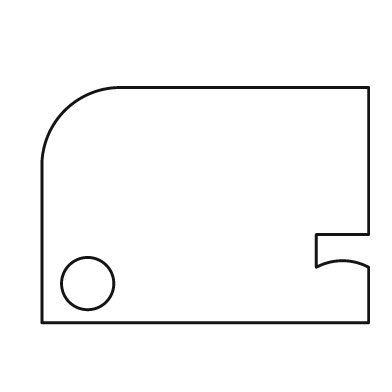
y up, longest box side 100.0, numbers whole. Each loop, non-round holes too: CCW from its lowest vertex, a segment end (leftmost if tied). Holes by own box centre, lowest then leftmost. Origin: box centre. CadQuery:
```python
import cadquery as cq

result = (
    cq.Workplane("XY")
    .moveTo(-50.0, -36.0)
    .lineTo(50.0, -36.0)
    .lineTo(50.0, -19.0)
    .threePointArc((42.0, -17.0), (34.0, -19.0))
    .lineTo(34.0, -9.0)
    .lineTo(50.0, -9.0)
    .lineTo(50.0, 36.0)
    .lineTo(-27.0, 36.0)
    .threePointArc((-43.0, 29.0), (-50.0, 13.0))
    .close()
    .moveTo(-36.0, -24.0)
    .circle(8.0)
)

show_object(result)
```